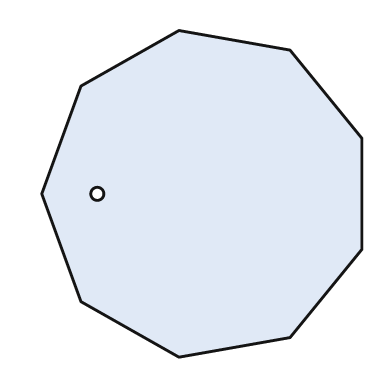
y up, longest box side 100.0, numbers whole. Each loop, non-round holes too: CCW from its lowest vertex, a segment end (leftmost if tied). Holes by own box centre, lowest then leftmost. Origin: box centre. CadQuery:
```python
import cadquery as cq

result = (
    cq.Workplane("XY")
    .moveTo(-7.0, -50.0)
    .lineTo(27.0, -44.0)
    .lineTo(49.0, -17.0)
    .lineTo(49.0, 17.0)
    .lineTo(27.0, 44.0)
    .lineTo(-7.0, 50.0)
    .lineTo(-37.0, 33.0)
    .lineTo(-49.0, 0.0)
    .lineTo(-37.0, -33.0)
    .close()
    .moveTo(-32.0, 0.0)
    .circle(2.0)
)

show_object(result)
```